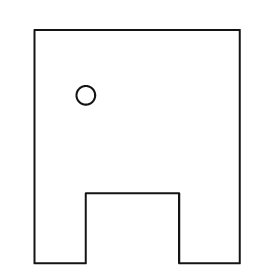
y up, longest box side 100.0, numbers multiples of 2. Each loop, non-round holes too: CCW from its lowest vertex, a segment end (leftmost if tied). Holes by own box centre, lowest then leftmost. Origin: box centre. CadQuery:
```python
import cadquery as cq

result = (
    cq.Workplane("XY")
    .moveTo(-44.0, -50.0)
    .lineTo(-22.0, -50.0)
    .lineTo(-22.0, -20.0)
    .lineTo(18.0, -20.0)
    .lineTo(18.0, -50.0)
    .lineTo(44.0, -50.0)
    .lineTo(44.0, 50.0)
    .lineTo(-44.0, 50.0)
    .close()
    .moveTo(-22.0, 22.0)
    .circle(4.0)
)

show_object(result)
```